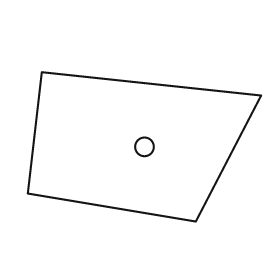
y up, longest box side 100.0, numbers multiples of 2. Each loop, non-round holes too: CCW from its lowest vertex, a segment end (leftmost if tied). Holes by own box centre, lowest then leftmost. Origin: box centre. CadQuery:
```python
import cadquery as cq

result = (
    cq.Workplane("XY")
    .moveTo(22.0, -32.0)
    .lineTo(50.0, 22.0)
    .lineTo(-44.0, 32.0)
    .lineTo(-50.0, -20.0)
    .close()
    .moveTo(0.0, 0.0)
    .circle(4.0)
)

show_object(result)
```